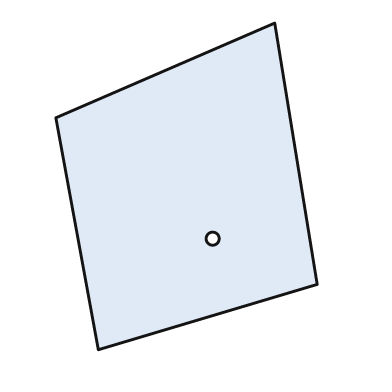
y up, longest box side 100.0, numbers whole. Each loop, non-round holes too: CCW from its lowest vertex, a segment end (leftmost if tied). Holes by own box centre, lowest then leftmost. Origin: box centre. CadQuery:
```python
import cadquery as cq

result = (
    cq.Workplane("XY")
    .moveTo(-27.0, -50.0)
    .lineTo(40.0, -30.0)
    .lineTo(27.0, 50.0)
    .lineTo(-40.0, 21.0)
    .close()
    .moveTo(8.0, -16.0)
    .circle(2.0)
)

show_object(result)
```